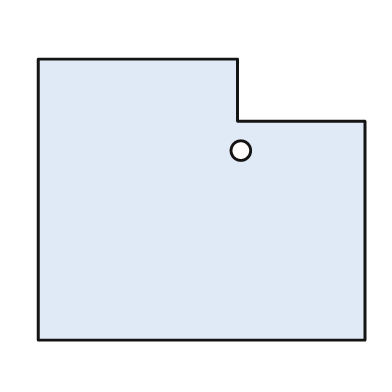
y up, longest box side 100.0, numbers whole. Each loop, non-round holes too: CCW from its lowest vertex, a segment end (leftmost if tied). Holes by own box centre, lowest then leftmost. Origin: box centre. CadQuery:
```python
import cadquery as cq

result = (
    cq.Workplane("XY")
    .moveTo(-50.0, -43.0)
    .lineTo(50.0, -43.0)
    .lineTo(50.0, 24.0)
    .lineTo(11.0, 24.0)
    .lineTo(11.0, 43.0)
    .lineTo(-50.0, 43.0)
    .close()
    .moveTo(12.0, 15.0)
    .circle(3.0)
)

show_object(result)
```